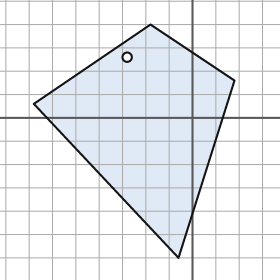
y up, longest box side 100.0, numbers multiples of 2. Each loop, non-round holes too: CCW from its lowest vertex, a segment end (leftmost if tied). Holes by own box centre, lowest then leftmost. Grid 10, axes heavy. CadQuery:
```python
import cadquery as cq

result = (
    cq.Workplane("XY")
    .moveTo(-6.0, -60.0)
    .lineTo(18.0, 16.0)
    .lineTo(-18.0, 40.0)
    .lineTo(-68.0, 6.0)
    .close()
    .moveTo(-28.0, 26.0)
    .circle(2.0)
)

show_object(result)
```